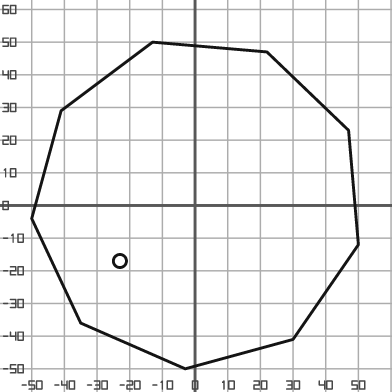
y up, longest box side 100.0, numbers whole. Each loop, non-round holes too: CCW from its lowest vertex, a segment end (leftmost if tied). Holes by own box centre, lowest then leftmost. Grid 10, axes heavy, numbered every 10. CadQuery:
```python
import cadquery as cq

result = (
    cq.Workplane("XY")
    .moveTo(-3.0, -50.0)
    .lineTo(30.0, -41.0)
    .lineTo(50.0, -12.0)
    .lineTo(47.0, 23.0)
    .lineTo(22.0, 47.0)
    .lineTo(-13.0, 50.0)
    .lineTo(-41.0, 29.0)
    .lineTo(-50.0, -4.0)
    .lineTo(-35.0, -36.0)
    .close()
    .moveTo(-23.0, -17.0)
    .circle(2.0)
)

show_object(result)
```